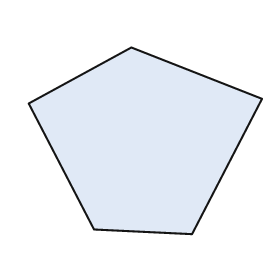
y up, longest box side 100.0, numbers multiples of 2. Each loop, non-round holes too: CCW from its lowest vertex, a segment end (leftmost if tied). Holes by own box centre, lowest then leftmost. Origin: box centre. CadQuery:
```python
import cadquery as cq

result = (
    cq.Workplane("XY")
    .moveTo(20.0, -40.0)
    .lineTo(50.0, 18.0)
    .lineTo(-6.0, 40.0)
    .lineTo(-50.0, 16.0)
    .lineTo(-22.0, -38.0)
    .close()
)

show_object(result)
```